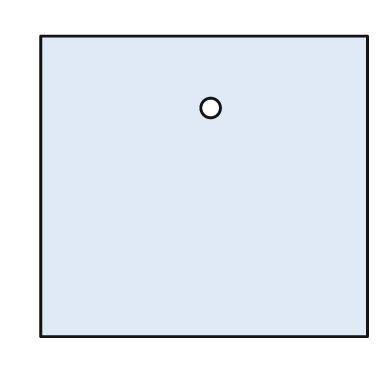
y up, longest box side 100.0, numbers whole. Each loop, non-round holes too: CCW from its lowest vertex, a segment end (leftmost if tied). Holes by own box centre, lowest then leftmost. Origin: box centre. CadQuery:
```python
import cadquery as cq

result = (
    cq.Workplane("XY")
    .moveTo(-50.0, -46.0)
    .lineTo(50.0, -46.0)
    .lineTo(50.0, 46.0)
    .lineTo(-50.0, 46.0)
    .close()
    .moveTo(2.0, 24.0)
    .circle(3.0)
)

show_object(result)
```